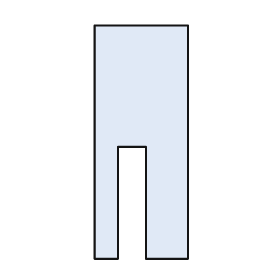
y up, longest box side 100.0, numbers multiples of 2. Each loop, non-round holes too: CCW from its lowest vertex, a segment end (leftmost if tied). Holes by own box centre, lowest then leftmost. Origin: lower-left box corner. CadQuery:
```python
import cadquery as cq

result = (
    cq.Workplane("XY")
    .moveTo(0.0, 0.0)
    .lineTo(10.0, 0.0)
    .lineTo(10.0, 48.0)
    .lineTo(22.0, 48.0)
    .lineTo(22.0, 0.0)
    .lineTo(40.0, 0.0)
    .lineTo(40.0, 100.0)
    .lineTo(0.0, 100.0)
    .close()
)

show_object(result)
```